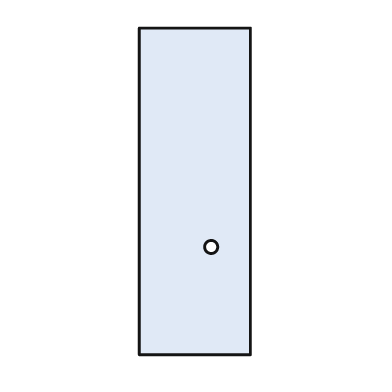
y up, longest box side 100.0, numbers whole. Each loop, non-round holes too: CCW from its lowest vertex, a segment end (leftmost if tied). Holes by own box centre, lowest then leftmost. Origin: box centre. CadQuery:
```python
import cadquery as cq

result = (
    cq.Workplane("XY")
    .moveTo(-17.0, -50.0)
    .lineTo(17.0, -50.0)
    .lineTo(17.0, 50.0)
    .lineTo(-17.0, 50.0)
    .close()
    .moveTo(5.0, -17.0)
    .circle(2.0)
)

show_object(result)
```